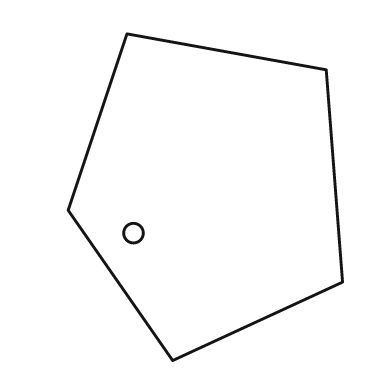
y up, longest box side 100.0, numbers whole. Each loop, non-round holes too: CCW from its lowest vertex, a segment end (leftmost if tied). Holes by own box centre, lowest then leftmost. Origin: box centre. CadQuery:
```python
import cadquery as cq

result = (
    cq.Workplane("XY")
    .moveTo(-10.0, -50.0)
    .lineTo(42.0, -26.0)
    .lineTo(37.0, 39.0)
    .lineTo(-24.0, 50.0)
    .lineTo(-42.0, -4.0)
    .close()
    .moveTo(-22.0, -11.0)
    .circle(3.0)
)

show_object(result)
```